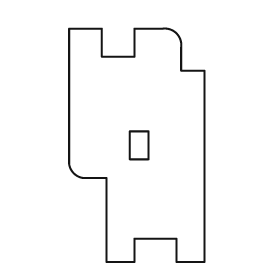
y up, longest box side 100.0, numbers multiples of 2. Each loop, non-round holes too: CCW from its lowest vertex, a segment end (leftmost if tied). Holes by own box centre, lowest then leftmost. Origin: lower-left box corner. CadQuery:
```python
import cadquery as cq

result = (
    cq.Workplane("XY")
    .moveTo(16.0, 0.0)
    .lineTo(28.0, 0.0)
    .lineTo(28.0, 10.0)
    .lineTo(46.0, 10.0)
    .lineTo(46.0, 0.0)
    .lineTo(58.0, 0.0)
    .lineTo(58.0, 82.0)
    .lineTo(48.0, 82.0)
    .lineTo(48.0, 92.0)
    .threePointArc((46.0, 98.0), (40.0, 100.0))
    .lineTo(28.0, 100.0)
    .lineTo(28.0, 88.0)
    .lineTo(14.0, 88.0)
    .lineTo(14.0, 100.0)
    .lineTo(0.0, 100.0)
    .lineTo(0.0, 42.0)
    .threePointArc((2.0, 38.0), (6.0, 36.0))
    .lineTo(16.0, 36.0)
    .close()
    .moveTo(26.0, 44.0)
    .lineTo(34.0, 44.0)
    .lineTo(34.0, 56.0)
    .lineTo(26.0, 56.0)
    .close()
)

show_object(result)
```